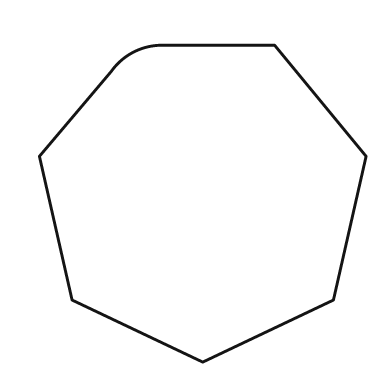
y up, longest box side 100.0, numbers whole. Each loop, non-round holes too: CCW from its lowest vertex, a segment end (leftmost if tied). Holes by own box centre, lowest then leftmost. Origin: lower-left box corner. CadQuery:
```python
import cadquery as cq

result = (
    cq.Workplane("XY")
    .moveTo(50.0, 0.0)
    .lineTo(90.0, 19.0)
    .lineTo(100.0, 63.0)
    .lineTo(72.0, 97.0)
    .lineTo(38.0, 97.0)
    .threePointArc((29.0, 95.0), (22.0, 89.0))
    .lineTo(0.0, 63.0)
    .lineTo(10.0, 19.0)
    .close()
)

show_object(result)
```